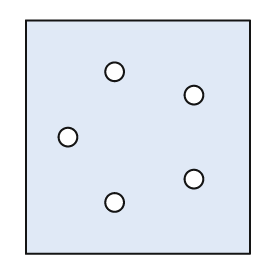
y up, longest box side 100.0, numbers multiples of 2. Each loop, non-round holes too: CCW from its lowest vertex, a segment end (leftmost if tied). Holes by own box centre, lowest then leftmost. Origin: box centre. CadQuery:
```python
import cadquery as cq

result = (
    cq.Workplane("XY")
    .moveTo(-48.0, -50.0)
    .lineTo(48.0, -50.0)
    .lineTo(48.0, 50.0)
    .lineTo(-48.0, 50.0)
    .close()
    .moveTo(-10.0, -28.0)
    .circle(4.0)
    .moveTo(24.0, -18.0)
    .circle(4.0)
    .moveTo(-30.0, 0.0)
    .circle(4.0)
    .moveTo(24.0, 18.0)
    .circle(4.0)
    .moveTo(-10.0, 28.0)
    .circle(4.0)
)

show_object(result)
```